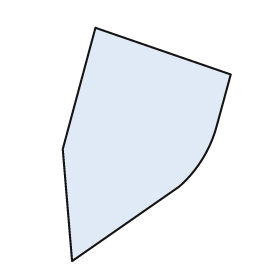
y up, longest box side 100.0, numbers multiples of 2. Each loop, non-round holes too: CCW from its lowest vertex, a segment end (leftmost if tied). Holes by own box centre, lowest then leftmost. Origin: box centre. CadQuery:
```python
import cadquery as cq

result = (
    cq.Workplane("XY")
    .moveTo(-32.0, -50.0)
    .lineTo(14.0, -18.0)
    .threePointArc((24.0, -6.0), (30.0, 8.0))
    .lineTo(36.0, 30.0)
    .lineTo(-22.0, 50.0)
    .lineTo(-36.0, -2.0)
    .close()
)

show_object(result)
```